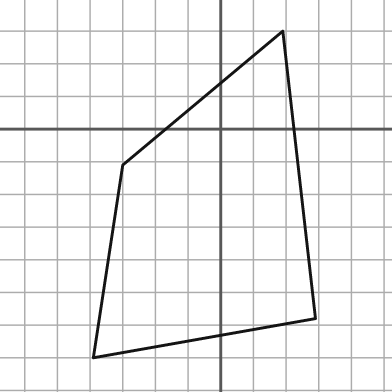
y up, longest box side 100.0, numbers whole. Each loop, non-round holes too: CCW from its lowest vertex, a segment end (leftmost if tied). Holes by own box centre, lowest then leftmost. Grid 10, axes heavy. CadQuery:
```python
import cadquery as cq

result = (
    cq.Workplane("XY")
    .moveTo(-39.0, -70.0)
    .lineTo(29.0, -58.0)
    .lineTo(19.0, 30.0)
    .lineTo(-30.0, -11.0)
    .close()
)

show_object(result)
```